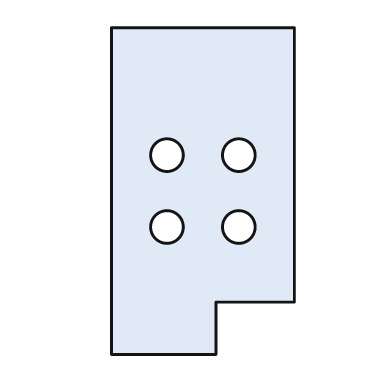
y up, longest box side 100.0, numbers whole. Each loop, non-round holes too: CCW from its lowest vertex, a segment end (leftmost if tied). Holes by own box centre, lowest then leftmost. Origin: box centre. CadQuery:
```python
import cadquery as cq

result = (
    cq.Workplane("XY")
    .moveTo(-28.0, -50.0)
    .lineTo(4.0, -50.0)
    .lineTo(4.0, -34.0)
    .lineTo(28.0, -34.0)
    .lineTo(28.0, 50.0)
    .lineTo(-28.0, 50.0)
    .close()
    .moveTo(-11.0, -11.0)
    .circle(5.0)
    .moveTo(11.0, -11.0)
    .circle(5.0)
    .moveTo(-11.0, 11.0)
    .circle(5.0)
    .moveTo(11.0, 11.0)
    .circle(5.0)
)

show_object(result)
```